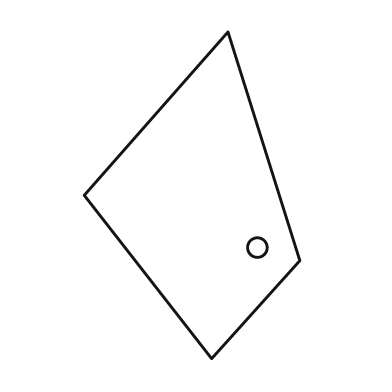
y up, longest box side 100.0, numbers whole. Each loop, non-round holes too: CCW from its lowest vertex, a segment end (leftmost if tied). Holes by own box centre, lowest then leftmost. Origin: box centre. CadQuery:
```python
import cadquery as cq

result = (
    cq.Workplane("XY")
    .moveTo(6.0, -50.0)
    .lineTo(33.0, -20.0)
    .lineTo(11.0, 50.0)
    .lineTo(-33.0, 0.0)
    .close()
    .moveTo(20.0, -16.0)
    .circle(3.0)
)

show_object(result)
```